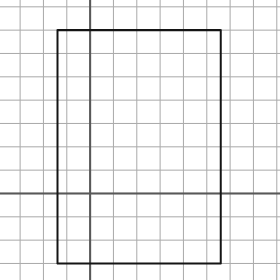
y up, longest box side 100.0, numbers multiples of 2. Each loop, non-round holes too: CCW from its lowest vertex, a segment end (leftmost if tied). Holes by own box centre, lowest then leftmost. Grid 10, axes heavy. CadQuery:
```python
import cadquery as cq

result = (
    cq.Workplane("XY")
    .moveTo(-14.0, -30.0)
    .lineTo(56.0, -30.0)
    .lineTo(56.0, 70.0)
    .lineTo(-14.0, 70.0)
    .close()
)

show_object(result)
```